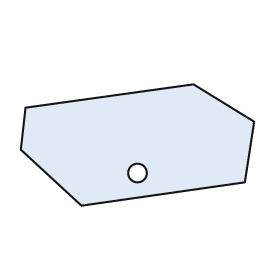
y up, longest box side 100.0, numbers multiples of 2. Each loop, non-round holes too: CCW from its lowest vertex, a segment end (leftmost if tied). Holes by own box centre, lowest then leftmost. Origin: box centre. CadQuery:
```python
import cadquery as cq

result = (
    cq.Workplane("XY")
    .moveTo(-24.0, -26.0)
    .lineTo(46.0, -16.0)
    .lineTo(50.0, 10.0)
    .lineTo(24.0, 26.0)
    .lineTo(-48.0, 16.0)
    .lineTo(-50.0, -2.0)
    .close()
    .moveTo(0.0, -12.0)
    .circle(4.0)
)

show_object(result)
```